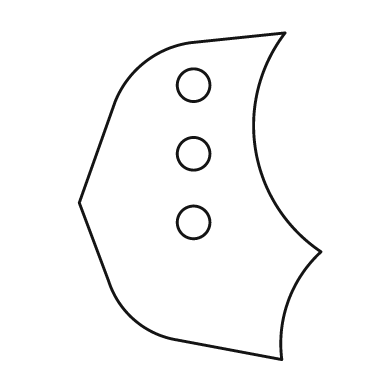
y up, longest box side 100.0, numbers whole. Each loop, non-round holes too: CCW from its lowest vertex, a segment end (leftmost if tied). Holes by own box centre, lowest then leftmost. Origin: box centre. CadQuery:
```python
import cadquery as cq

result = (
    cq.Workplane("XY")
    .moveTo(25.0, -50.0)
    .threePointArc((27.0, -32.0), (37.0, -17.0))
    .threePointArc((17.0, 14.0), (26.0, 50.0))
    .lineTo(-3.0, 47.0)
    .threePointArc((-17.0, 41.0), (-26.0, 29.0))
    .lineTo(-37.0, -2.0)
    .lineTo(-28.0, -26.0)
    .threePointArc((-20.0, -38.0), (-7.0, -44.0))
    .close()
    .moveTo(-2.0, -8.0)
    .circle(5.0)
    .moveTo(-2.0, 13.0)
    .circle(5.0)
    .moveTo(-2.0, 34.0)
    .circle(5.0)
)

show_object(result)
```